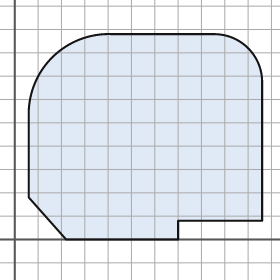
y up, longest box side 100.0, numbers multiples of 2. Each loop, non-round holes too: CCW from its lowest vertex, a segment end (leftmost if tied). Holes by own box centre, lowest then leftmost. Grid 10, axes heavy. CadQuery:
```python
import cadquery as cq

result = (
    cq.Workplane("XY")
    .moveTo(22.0, 0.0)
    .lineTo(70.0, 0.0)
    .lineTo(70.0, 8.0)
    .lineTo(106.0, 8.0)
    .lineTo(106.0, 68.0)
    .threePointArc((100.0, 82.0), (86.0, 88.0))
    .lineTo(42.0, 88.0)
    .threePointArc((16.0, 78.0), (6.0, 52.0))
    .lineTo(6.0, 18.0)
    .close()
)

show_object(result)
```